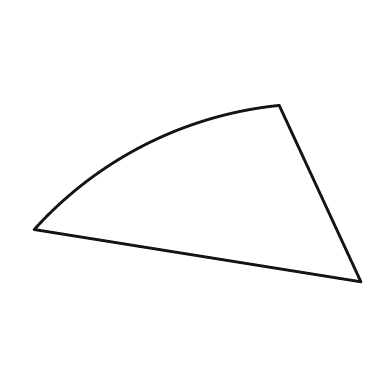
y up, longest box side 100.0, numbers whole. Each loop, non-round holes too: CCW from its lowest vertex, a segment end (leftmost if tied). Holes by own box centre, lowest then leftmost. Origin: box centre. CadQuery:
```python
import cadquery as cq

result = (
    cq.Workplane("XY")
    .moveTo(50.0, -27.0)
    .lineTo(25.0, 27.0)
    .threePointArc((-16.0, 15.0), (-50.0, -11.0))
    .close()
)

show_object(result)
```